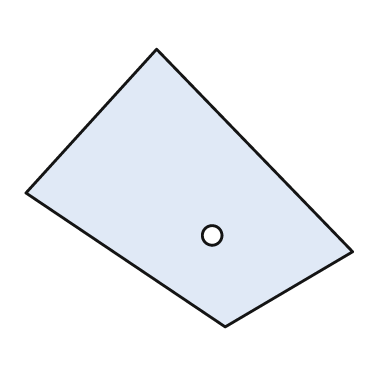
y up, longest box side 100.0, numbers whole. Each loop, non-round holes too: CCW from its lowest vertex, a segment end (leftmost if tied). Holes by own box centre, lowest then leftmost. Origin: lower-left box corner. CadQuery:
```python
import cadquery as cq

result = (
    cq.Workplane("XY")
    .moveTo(61.0, 0.0)
    .lineTo(100.0, 23.0)
    .lineTo(40.0, 85.0)
    .lineTo(0.0, 41.0)
    .close()
    .moveTo(57.0, 28.0)
    .circle(3.0)
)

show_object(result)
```